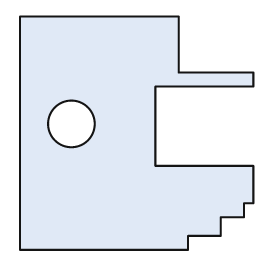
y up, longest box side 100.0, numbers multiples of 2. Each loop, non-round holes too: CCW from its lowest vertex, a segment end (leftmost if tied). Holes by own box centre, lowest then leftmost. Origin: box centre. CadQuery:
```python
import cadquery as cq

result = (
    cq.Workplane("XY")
    .moveTo(-50.0, -50.0)
    .lineTo(22.0, -50.0)
    .lineTo(22.0, -44.0)
    .lineTo(36.0, -44.0)
    .lineTo(36.0, -36.0)
    .lineTo(46.0, -36.0)
    .lineTo(46.0, -30.0)
    .lineTo(50.0, -30.0)
    .lineTo(50.0, -14.0)
    .lineTo(8.0, -14.0)
    .lineTo(8.0, 20.0)
    .lineTo(50.0, 20.0)
    .lineTo(50.0, 26.0)
    .lineTo(18.0, 26.0)
    .lineTo(18.0, 50.0)
    .lineTo(-50.0, 50.0)
    .close()
    .moveTo(-28.0, 4.0)
    .circle(10.0)
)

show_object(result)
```